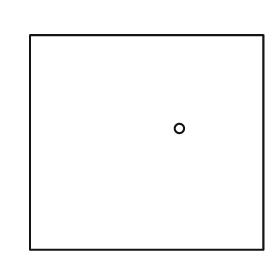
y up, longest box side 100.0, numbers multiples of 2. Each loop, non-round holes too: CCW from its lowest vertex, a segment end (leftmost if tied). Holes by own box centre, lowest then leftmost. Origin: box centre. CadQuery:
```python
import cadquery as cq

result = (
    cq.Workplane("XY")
    .moveTo(-50.0, -46.0)
    .lineTo(50.0, -46.0)
    .lineTo(50.0, 46.0)
    .lineTo(-50.0, 46.0)
    .close()
    .moveTo(14.0, 6.0)
    .circle(2.0)
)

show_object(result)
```